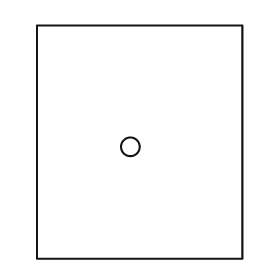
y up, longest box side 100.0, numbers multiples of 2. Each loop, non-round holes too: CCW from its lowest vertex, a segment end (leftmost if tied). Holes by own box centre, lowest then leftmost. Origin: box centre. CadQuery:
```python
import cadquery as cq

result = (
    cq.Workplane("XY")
    .moveTo(-44.0, -50.0)
    .lineTo(44.0, -50.0)
    .lineTo(44.0, 50.0)
    .lineTo(-44.0, 50.0)
    .close()
    .moveTo(-4.0, -2.0)
    .circle(4.0)
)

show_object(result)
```